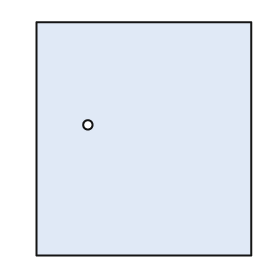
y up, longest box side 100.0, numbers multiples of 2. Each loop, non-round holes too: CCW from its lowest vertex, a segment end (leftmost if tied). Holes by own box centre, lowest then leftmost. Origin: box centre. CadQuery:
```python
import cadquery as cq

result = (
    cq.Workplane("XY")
    .moveTo(-46.0, -50.0)
    .lineTo(46.0, -50.0)
    .lineTo(46.0, 50.0)
    .lineTo(-46.0, 50.0)
    .close()
    .moveTo(-24.0, 6.0)
    .circle(2.0)
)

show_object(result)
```